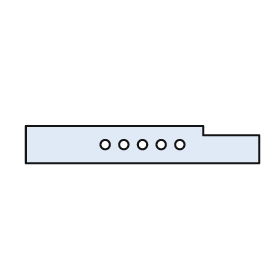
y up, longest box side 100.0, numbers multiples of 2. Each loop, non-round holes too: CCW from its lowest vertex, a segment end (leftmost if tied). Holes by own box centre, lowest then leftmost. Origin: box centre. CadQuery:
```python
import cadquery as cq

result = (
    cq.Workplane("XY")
    .moveTo(-50.0, -8.0)
    .lineTo(50.0, -8.0)
    .lineTo(50.0, 4.0)
    .lineTo(26.0, 4.0)
    .lineTo(26.0, 8.0)
    .lineTo(-50.0, 8.0)
    .close()
    .moveTo(-16.0, 0.0)
    .circle(2.0)
    .moveTo(-8.0, 0.0)
    .circle(2.0)
    .moveTo(0.0, 0.0)
    .circle(2.0)
    .moveTo(8.0, 0.0)
    .circle(2.0)
    .moveTo(16.0, 0.0)
    .circle(2.0)
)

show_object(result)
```